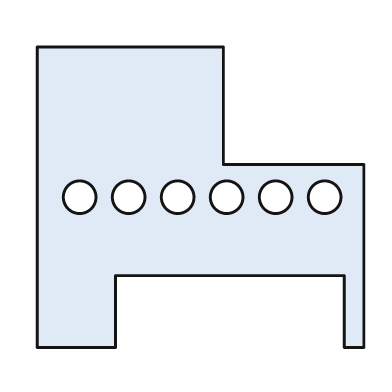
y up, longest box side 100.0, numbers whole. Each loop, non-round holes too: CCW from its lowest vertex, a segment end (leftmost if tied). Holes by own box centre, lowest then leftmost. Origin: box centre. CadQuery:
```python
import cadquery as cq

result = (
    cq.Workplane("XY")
    .moveTo(-50.0, -46.0)
    .lineTo(-26.0, -46.0)
    .lineTo(-26.0, -24.0)
    .lineTo(44.0, -24.0)
    .lineTo(44.0, -46.0)
    .lineTo(50.0, -46.0)
    .lineTo(50.0, 10.0)
    .lineTo(7.0, 10.0)
    .lineTo(7.0, 46.0)
    .lineTo(-50.0, 46.0)
    .close()
    .moveTo(-37.0, 0.0)
    .circle(5.0)
    .moveTo(-22.0, 0.0)
    .circle(5.0)
    .moveTo(-7.0, 0.0)
    .circle(5.0)
    .moveTo(8.0, 0.0)
    .circle(5.0)
    .moveTo(23.0, 0.0)
    .circle(5.0)
    .moveTo(38.0, 0.0)
    .circle(5.0)
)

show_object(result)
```